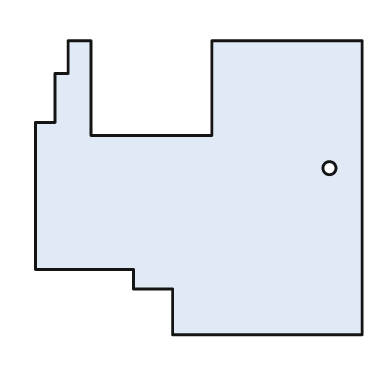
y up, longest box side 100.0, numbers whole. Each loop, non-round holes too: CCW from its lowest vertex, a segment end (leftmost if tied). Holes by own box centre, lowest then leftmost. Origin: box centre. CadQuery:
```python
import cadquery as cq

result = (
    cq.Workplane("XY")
    .moveTo(-8.0, -45.0)
    .lineTo(50.0, -45.0)
    .lineTo(50.0, 45.0)
    .lineTo(4.0, 45.0)
    .lineTo(4.0, 16.0)
    .lineTo(-33.0, 16.0)
    .lineTo(-33.0, 45.0)
    .lineTo(-40.0, 45.0)
    .lineTo(-40.0, 35.0)
    .lineTo(-44.0, 35.0)
    .lineTo(-44.0, 20.0)
    .lineTo(-50.0, 20.0)
    .lineTo(-50.0, -25.0)
    .lineTo(-20.0, -25.0)
    .lineTo(-20.0, -31.0)
    .lineTo(-8.0, -31.0)
    .close()
    .moveTo(40.0, 6.0)
    .circle(2.0)
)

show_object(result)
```